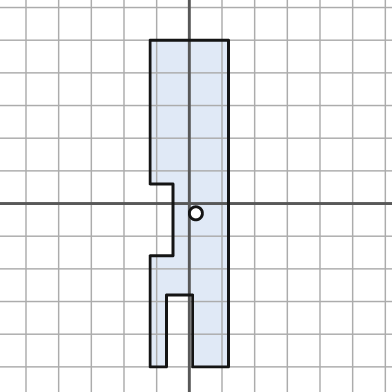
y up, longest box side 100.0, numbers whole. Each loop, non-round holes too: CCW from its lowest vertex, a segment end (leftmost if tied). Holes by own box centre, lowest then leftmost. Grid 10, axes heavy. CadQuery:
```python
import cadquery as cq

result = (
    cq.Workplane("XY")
    .moveTo(-12.0, -50.0)
    .lineTo(-7.0, -50.0)
    .lineTo(-7.0, -28.0)
    .lineTo(1.0, -28.0)
    .lineTo(1.0, -50.0)
    .lineTo(12.0, -50.0)
    .lineTo(12.0, 50.0)
    .lineTo(-12.0, 50.0)
    .lineTo(-12.0, 6.0)
    .lineTo(-5.0, 6.0)
    .lineTo(-5.0, -16.0)
    .lineTo(-12.0, -16.0)
    .close()
    .moveTo(2.0, -3.0)
    .circle(2.0)
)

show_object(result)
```